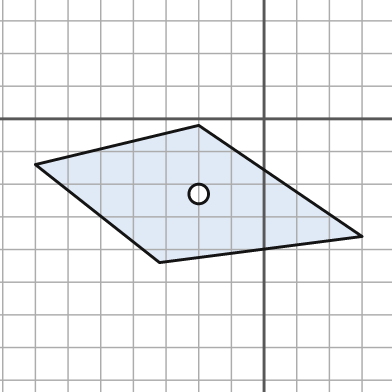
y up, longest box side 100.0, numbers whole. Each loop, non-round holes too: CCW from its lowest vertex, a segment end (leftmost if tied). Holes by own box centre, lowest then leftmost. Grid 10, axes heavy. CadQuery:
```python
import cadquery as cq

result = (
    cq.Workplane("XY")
    .moveTo(-32.0, -44.0)
    .lineTo(30.0, -36.0)
    .lineTo(-20.0, -2.0)
    .lineTo(-70.0, -14.0)
    .close()
    .moveTo(-20.0, -23.0)
    .circle(3.0)
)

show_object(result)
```